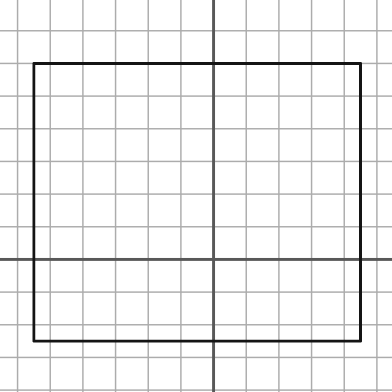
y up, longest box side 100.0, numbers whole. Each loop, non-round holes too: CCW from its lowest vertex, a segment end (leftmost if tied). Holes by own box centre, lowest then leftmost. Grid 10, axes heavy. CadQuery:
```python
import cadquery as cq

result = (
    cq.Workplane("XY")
    .moveTo(-55.0, -25.0)
    .lineTo(45.0, -25.0)
    .lineTo(45.0, 60.0)
    .lineTo(-55.0, 60.0)
    .close()
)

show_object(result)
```